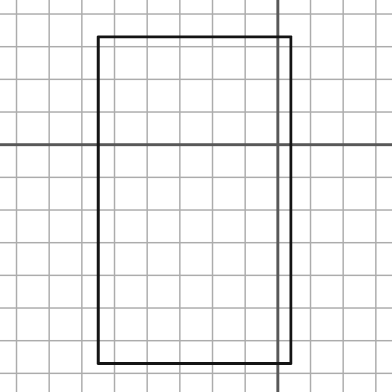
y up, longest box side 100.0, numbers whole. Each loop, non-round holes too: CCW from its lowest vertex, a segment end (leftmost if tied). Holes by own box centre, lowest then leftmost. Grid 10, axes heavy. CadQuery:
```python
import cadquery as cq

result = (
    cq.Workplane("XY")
    .moveTo(-55.0, -67.0)
    .lineTo(4.0, -67.0)
    .lineTo(4.0, 33.0)
    .lineTo(-55.0, 33.0)
    .close()
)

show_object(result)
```